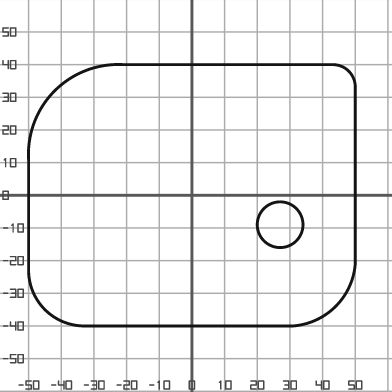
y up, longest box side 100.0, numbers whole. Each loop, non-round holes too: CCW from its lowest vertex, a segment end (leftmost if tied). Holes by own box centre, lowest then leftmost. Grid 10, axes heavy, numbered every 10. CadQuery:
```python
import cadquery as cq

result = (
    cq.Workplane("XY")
    .moveTo(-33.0, -40.0)
    .lineTo(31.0, -40.0)
    .threePointArc((44.0, -34.0), (50.0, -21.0))
    .lineTo(50.0, 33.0)
    .threePointArc((48.0, 38.0), (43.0, 40.0))
    .lineTo(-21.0, 40.0)
    .threePointArc((-42.0, 32.0), (-50.0, 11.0))
    .lineTo(-50.0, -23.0)
    .threePointArc((-45.0, -35.0), (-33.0, -40.0))
    .close()
    .moveTo(27.0, -9.0)
    .circle(7.0)
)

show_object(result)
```